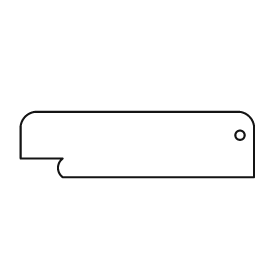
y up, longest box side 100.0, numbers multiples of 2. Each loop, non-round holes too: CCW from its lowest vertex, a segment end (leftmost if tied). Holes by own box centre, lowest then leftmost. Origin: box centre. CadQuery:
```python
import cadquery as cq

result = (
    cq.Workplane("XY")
    .moveTo(-32.0, -14.0)
    .lineTo(50.0, -14.0)
    .lineTo(50.0, 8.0)
    .threePointArc((48.0, 12.0), (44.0, 14.0))
    .lineTo(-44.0, 14.0)
    .threePointArc((-48.0, 12.0), (-50.0, 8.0))
    .lineTo(-50.0, -6.0)
    .lineTo(-32.0, -6.0)
    .threePointArc((-34.0, -10.0), (-32.0, -14.0))
    .close()
    .moveTo(44.0, 4.0)
    .circle(2.0)
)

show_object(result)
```